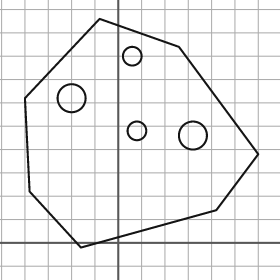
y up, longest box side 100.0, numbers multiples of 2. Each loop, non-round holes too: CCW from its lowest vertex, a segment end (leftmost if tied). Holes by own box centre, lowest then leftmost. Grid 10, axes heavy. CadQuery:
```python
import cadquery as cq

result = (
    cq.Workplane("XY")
    .moveTo(-16.0, -2.0)
    .lineTo(42.0, 14.0)
    .lineTo(60.0, 38.0)
    .lineTo(26.0, 84.0)
    .lineTo(-8.0, 96.0)
    .lineTo(-40.0, 62.0)
    .lineTo(-38.0, 22.0)
    .close()
    .moveTo(32.0, 46.0)
    .circle(6.0)
    .moveTo(8.0, 48.0)
    .circle(4.0)
    .moveTo(-20.0, 62.0)
    .circle(6.0)
    .moveTo(6.0, 80.0)
    .circle(4.0)
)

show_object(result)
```